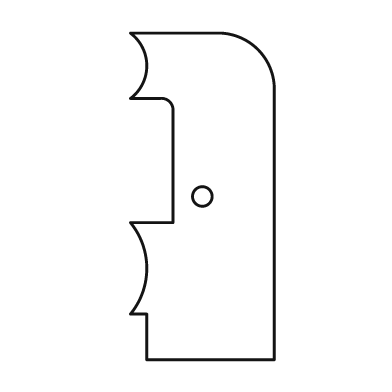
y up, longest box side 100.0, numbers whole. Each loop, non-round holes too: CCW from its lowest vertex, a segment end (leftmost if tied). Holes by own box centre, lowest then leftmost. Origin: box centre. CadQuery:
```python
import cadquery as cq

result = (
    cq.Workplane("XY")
    .moveTo(-17.0, -50.0)
    .lineTo(22.0, -50.0)
    .lineTo(22.0, 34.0)
    .threePointArc((17.0, 45.0), (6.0, 50.0))
    .lineTo(-22.0, 50.0)
    .threePointArc((-17.0, 40.0), (-22.0, 30.0))
    .lineTo(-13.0, 30.0)
    .threePointArc((-10.0, 29.0), (-9.0, 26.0))
    .lineTo(-9.0, -8.0)
    .lineTo(-22.0, -8.0)
    .threePointArc((-17.0, -22.0), (-22.0, -36.0))
    .lineTo(-17.0, -36.0)
    .close()
    .moveTo(0.0, 0.0)
    .circle(3.0)
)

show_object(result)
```